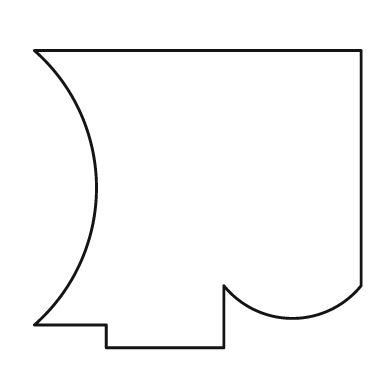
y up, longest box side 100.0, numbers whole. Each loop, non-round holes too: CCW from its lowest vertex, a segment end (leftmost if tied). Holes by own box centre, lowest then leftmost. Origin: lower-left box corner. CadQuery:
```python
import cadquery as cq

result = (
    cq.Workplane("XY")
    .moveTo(22.0, 0.0)
    .lineTo(58.0, 0.0)
    .lineTo(58.0, 19.0)
    .threePointArc((79.0, 9.0), (100.0, 19.0))
    .lineTo(100.0, 91.0)
    .lineTo(0.0, 91.0)
    .threePointArc((19.0, 49.0), (0.0, 7.0))
    .lineTo(22.0, 7.0)
    .close()
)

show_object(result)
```